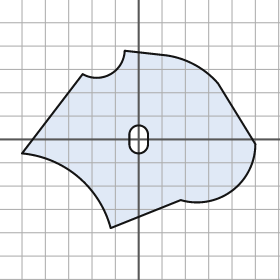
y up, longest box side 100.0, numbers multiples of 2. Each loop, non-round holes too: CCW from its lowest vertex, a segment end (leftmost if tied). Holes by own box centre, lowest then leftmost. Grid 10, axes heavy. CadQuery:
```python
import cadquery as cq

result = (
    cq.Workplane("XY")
    .moveTo(-12.0, -38.0)
    .lineTo(18.0, -26.0)
    .threePointArc((40.0, -22.0), (50.0, -2.0))
    .lineTo(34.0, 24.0)
    .threePointArc((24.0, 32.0), (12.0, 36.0))
    .lineTo(-6.0, 38.0)
    .threePointArc((-12.0, 28.0), (-24.0, 28.0))
    .lineTo(-50.0, -6.0)
    .threePointArc((-26.0, -16.0), (-12.0, -38.0))
    .close()
    .moveTo(-4.0, -2.0)
    .threePointArc((0.0, -6.0), (4.0, -2.0))
    .lineTo(4.0, 2.0)
    .threePointArc((0.0, 6.0), (-4.0, 2.0))
    .close()
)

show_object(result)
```